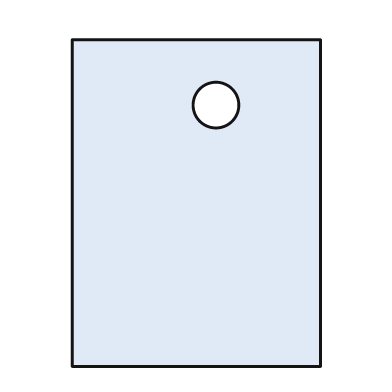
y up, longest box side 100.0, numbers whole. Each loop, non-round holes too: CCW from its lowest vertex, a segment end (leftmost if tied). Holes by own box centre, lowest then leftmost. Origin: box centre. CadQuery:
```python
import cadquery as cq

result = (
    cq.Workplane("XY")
    .moveTo(-38.0, -50.0)
    .lineTo(38.0, -50.0)
    .lineTo(38.0, 50.0)
    .lineTo(-38.0, 50.0)
    .close()
    .moveTo(6.0, 30.0)
    .circle(7.0)
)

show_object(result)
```